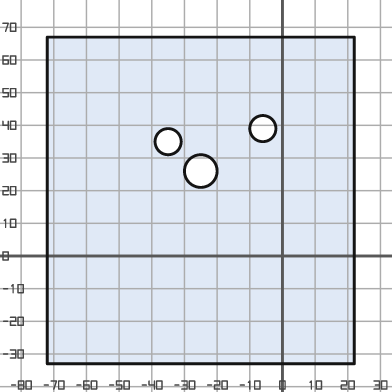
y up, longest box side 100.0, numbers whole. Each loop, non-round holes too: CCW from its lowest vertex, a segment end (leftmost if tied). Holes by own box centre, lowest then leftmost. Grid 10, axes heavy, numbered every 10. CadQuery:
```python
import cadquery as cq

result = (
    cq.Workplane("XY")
    .moveTo(-72.0, -33.0)
    .lineTo(22.0, -33.0)
    .lineTo(22.0, 67.0)
    .lineTo(-72.0, 67.0)
    .close()
    .moveTo(-25.0, 26.0)
    .circle(5.0)
    .moveTo(-35.0, 35.0)
    .circle(4.0)
    .moveTo(-6.0, 39.0)
    .circle(4.0)
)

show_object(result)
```